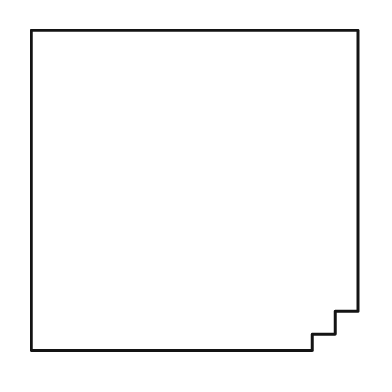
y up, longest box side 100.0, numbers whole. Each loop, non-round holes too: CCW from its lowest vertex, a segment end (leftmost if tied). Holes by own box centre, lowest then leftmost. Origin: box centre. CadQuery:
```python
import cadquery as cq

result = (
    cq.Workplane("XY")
    .moveTo(-50.0, -49.0)
    .lineTo(36.0, -49.0)
    .lineTo(36.0, -44.0)
    .lineTo(43.0, -44.0)
    .lineTo(43.0, -37.0)
    .lineTo(50.0, -37.0)
    .lineTo(50.0, 49.0)
    .lineTo(-50.0, 49.0)
    .close()
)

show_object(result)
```